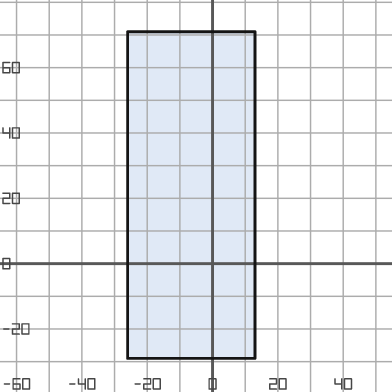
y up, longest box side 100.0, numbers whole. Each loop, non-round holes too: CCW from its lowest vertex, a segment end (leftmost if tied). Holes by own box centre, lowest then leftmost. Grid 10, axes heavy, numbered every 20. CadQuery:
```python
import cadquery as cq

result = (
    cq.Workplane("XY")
    .moveTo(-26.0, -29.0)
    .lineTo(13.0, -29.0)
    .lineTo(13.0, 71.0)
    .lineTo(-26.0, 71.0)
    .close()
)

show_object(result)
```